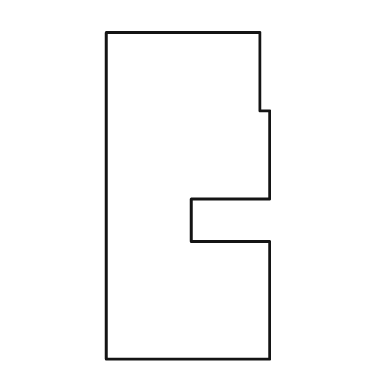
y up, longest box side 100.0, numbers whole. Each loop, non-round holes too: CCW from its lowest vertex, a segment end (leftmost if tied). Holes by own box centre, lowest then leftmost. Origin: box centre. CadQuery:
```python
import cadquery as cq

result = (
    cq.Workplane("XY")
    .moveTo(-25.0, -50.0)
    .lineTo(25.0, -50.0)
    .lineTo(25.0, -14.0)
    .lineTo(1.0, -14.0)
    .lineTo(1.0, -1.0)
    .lineTo(25.0, -1.0)
    .lineTo(25.0, 26.0)
    .lineTo(22.0, 26.0)
    .lineTo(22.0, 50.0)
    .lineTo(-25.0, 50.0)
    .close()
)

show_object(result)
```